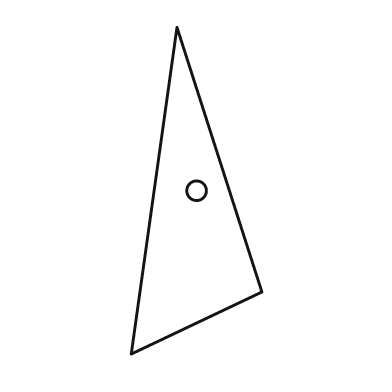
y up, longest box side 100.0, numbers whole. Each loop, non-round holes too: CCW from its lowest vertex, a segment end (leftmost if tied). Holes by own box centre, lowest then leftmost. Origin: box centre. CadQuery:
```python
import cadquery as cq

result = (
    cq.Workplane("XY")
    .moveTo(-20.0, -50.0)
    .lineTo(20.0, -31.0)
    .lineTo(-6.0, 50.0)
    .close()
    .moveTo(0.0, 0.0)
    .circle(3.0)
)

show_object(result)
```